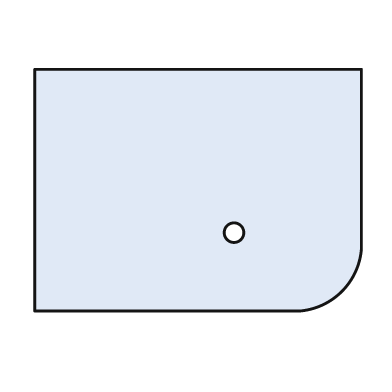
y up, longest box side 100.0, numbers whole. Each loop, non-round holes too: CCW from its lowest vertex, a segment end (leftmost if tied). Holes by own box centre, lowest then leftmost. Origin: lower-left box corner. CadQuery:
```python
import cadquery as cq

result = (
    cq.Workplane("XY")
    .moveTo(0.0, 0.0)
    .lineTo(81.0, 0.0)
    .threePointArc((94.0, 6.0), (100.0, 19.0))
    .lineTo(100.0, 74.0)
    .lineTo(0.0, 74.0)
    .close()
    .moveTo(61.0, 24.0)
    .circle(3.0)
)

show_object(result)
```